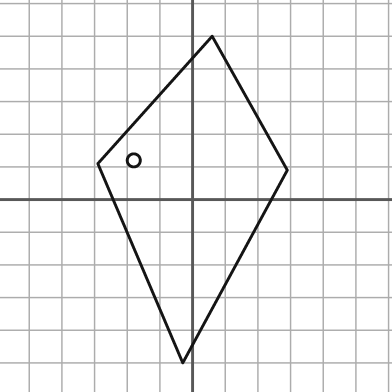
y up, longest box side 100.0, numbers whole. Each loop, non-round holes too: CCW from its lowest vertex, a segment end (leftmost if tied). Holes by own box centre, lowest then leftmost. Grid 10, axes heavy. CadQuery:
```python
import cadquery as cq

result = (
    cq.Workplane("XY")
    .moveTo(-3.0, -50.0)
    .lineTo(29.0, 9.0)
    .lineTo(6.0, 50.0)
    .lineTo(-29.0, 11.0)
    .close()
    .moveTo(-18.0, 12.0)
    .circle(2.0)
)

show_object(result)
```